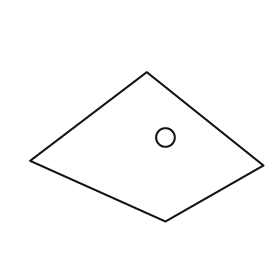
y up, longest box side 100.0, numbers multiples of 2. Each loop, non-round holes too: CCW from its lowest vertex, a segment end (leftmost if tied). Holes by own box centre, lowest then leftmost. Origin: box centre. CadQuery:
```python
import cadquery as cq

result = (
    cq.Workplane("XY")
    .moveTo(8.0, -32.0)
    .lineTo(50.0, -8.0)
    .lineTo(0.0, 32.0)
    .lineTo(-50.0, -6.0)
    .close()
    .moveTo(8.0, 4.0)
    .circle(4.0)
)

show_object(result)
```